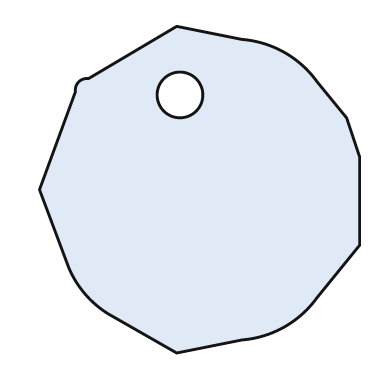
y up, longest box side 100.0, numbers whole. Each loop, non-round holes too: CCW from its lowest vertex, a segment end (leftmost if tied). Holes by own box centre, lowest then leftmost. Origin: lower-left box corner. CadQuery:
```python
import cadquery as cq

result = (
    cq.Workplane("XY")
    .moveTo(42.0, 0.0)
    .lineTo(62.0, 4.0)
    .threePointArc((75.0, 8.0), (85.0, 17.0))
    .lineTo(98.0, 33.0)
    .lineTo(98.0, 60.0)
    .lineTo(94.0, 72.0)
    .lineTo(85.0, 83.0)
    .threePointArc((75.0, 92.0), (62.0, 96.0))
    .lineTo(42.0, 100.0)
    .lineTo(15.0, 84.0)
    .threePointArc((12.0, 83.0), (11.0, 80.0))
    .lineTo(0.0, 50.0)
    .lineTo(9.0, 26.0)
    .threePointArc((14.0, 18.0), (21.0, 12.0))
    .close()
    .moveTo(43.0, 79.0)
    .circle(7.0)
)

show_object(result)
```